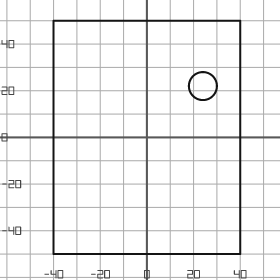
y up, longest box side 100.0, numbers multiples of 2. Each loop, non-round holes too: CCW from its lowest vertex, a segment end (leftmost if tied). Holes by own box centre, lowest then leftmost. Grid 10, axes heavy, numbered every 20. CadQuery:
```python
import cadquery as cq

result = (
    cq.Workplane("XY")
    .moveTo(-40.0, -50.0)
    .lineTo(40.0, -50.0)
    .lineTo(40.0, 50.0)
    .lineTo(-40.0, 50.0)
    .close()
    .moveTo(24.0, 22.0)
    .circle(6.0)
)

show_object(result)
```